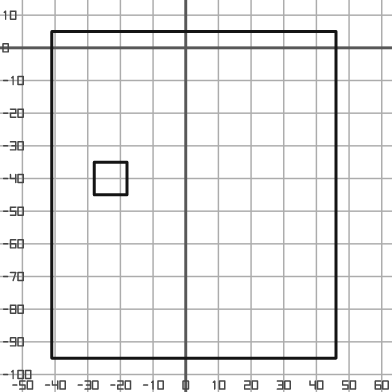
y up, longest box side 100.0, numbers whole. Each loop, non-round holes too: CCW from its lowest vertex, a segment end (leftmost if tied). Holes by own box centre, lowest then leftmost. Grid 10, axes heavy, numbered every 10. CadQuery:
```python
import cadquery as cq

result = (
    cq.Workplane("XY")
    .moveTo(-41.0, -95.0)
    .lineTo(46.0, -95.0)
    .lineTo(46.0, 5.0)
    .lineTo(-41.0, 5.0)
    .close()
    .moveTo(-28.0, -45.0)
    .lineTo(-18.0, -45.0)
    .lineTo(-18.0, -35.0)
    .lineTo(-28.0, -35.0)
    .close()
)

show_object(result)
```